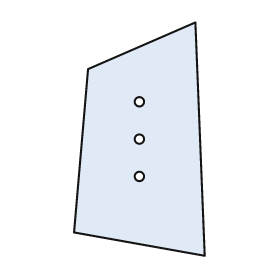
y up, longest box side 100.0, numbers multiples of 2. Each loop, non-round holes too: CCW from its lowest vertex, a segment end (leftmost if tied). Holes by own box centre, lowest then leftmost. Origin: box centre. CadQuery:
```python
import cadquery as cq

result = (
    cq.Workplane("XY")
    .moveTo(28.0, -50.0)
    .lineTo(24.0, 50.0)
    .lineTo(-22.0, 30.0)
    .lineTo(-28.0, -40.0)
    .close()
    .moveTo(0.0, -16.0)
    .circle(2.0)
    .moveTo(0.0, 0.0)
    .circle(2.0)
    .moveTo(0.0, 16.0)
    .circle(2.0)
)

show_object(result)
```